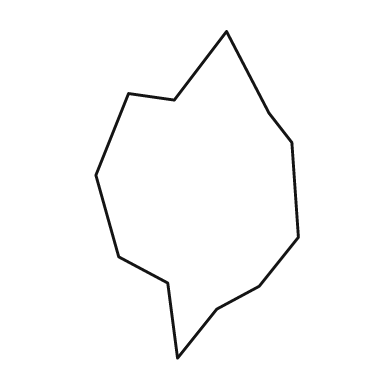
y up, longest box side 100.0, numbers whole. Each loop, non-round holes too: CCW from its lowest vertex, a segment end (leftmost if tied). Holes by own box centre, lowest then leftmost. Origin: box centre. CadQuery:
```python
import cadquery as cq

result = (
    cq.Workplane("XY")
    .moveTo(-6.0, -50.0)
    .lineTo(6.0, -35.0)
    .lineTo(19.0, -28.0)
    .lineTo(31.0, -13.0)
    .lineTo(29.0, 16.0)
    .lineTo(22.0, 25.0)
    .lineTo(9.0, 50.0)
    .lineTo(-7.0, 29.0)
    .lineTo(-21.0, 31.0)
    .lineTo(-31.0, 6.0)
    .lineTo(-24.0, -19.0)
    .lineTo(-9.0, -27.0)
    .close()
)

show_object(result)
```